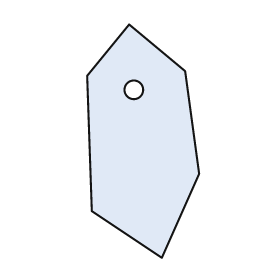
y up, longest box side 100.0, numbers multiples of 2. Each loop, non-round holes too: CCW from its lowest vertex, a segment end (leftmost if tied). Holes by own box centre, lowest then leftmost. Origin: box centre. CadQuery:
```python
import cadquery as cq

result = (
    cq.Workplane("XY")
    .moveTo(8.0, -50.0)
    .lineTo(24.0, -14.0)
    .lineTo(18.0, 30.0)
    .lineTo(-6.0, 50.0)
    .lineTo(-24.0, 28.0)
    .lineTo(-22.0, -30.0)
    .close()
    .moveTo(-4.0, 22.0)
    .circle(4.0)
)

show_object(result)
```